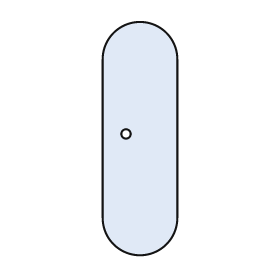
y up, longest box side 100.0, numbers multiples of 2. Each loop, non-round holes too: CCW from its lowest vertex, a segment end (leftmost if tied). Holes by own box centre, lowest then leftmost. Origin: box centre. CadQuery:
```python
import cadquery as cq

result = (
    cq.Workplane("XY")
    .moveTo(-16.0, -34.0)
    .threePointArc((0.0, -50.0), (16.0, -34.0))
    .lineTo(16.0, 34.0)
    .threePointArc((0.0, 50.0), (-16.0, 34.0))
    .close()
    .moveTo(-6.0, 2.0)
    .circle(2.0)
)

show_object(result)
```